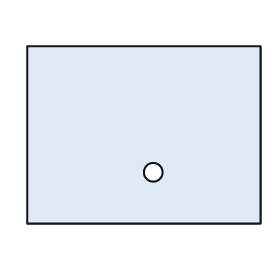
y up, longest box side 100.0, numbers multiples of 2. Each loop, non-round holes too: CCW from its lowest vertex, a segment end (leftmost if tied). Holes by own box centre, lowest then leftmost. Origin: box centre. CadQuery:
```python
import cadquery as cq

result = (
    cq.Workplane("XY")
    .moveTo(-50.0, -38.0)
    .lineTo(50.0, -38.0)
    .lineTo(50.0, 38.0)
    .lineTo(-50.0, 38.0)
    .close()
    .moveTo(4.0, -16.0)
    .circle(4.0)
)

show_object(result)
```